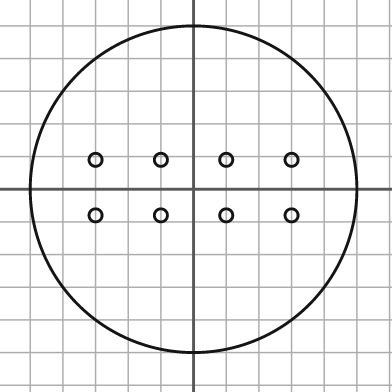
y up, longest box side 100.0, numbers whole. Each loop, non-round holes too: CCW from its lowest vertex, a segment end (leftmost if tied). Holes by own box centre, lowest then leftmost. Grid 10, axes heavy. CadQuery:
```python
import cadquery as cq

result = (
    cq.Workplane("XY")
    .moveTo(0.0, 0.0)
    .circle(50.0)
    .moveTo(-30.0, -8.0)
    .circle(2.0)
    .moveTo(-10.0, -8.0)
    .circle(2.0)
    .moveTo(10.0, -8.0)
    .circle(2.0)
    .moveTo(30.0, -8.0)
    .circle(2.0)
    .moveTo(-30.0, 9.0)
    .circle(2.0)
    .moveTo(-10.0, 9.0)
    .circle(2.0)
    .moveTo(10.0, 9.0)
    .circle(2.0)
    .moveTo(30.0, 9.0)
    .circle(2.0)
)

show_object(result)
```